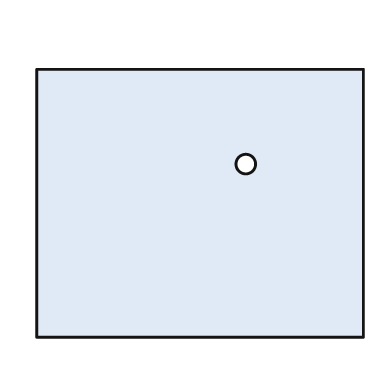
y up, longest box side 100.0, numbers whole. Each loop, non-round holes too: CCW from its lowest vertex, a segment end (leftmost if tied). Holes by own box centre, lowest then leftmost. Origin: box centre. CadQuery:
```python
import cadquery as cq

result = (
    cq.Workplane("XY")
    .moveTo(-50.0, -41.0)
    .lineTo(50.0, -41.0)
    .lineTo(50.0, 41.0)
    .lineTo(-50.0, 41.0)
    .close()
    .moveTo(14.0, 12.0)
    .circle(3.0)
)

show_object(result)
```